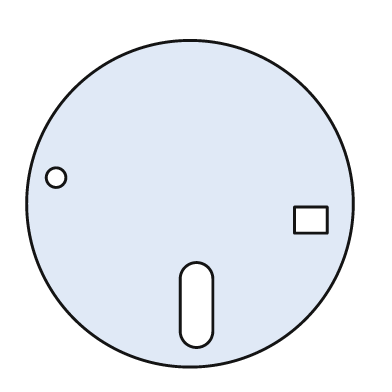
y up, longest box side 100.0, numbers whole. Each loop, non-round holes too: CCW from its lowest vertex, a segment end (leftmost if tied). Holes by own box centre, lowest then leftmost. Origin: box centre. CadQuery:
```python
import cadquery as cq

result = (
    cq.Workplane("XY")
    .moveTo(0.0, 0.0)
    .circle(50.0)
    .moveTo(-3.0, -39.0)
    .threePointArc((2.0, -44.0), (7.0, -39.0))
    .lineTo(7.0, -23.0)
    .threePointArc((2.0, -18.0), (-3.0, -23.0))
    .close()
    .moveTo(32.0, -9.0)
    .lineTo(42.0, -9.0)
    .lineTo(42.0, -1.0)
    .lineTo(32.0, -1.0)
    .close()
    .moveTo(-41.0, 8.0)
    .circle(3.0)
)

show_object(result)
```